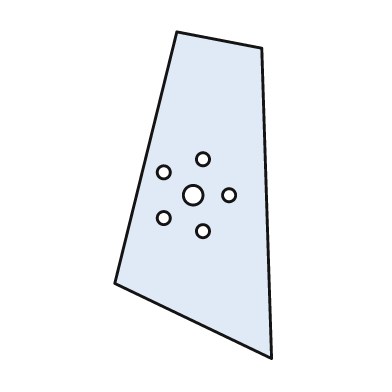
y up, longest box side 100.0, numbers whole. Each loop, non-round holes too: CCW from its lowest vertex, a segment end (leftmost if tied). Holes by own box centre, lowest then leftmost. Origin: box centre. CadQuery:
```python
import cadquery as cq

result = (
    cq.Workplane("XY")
    .moveTo(24.0, -50.0)
    .lineTo(21.0, 45.0)
    .lineTo(-5.0, 50.0)
    .lineTo(-24.0, -27.0)
    .close()
    .moveTo(3.0, -11.0)
    .circle(2.0)
    .moveTo(-9.0, -7.0)
    .circle(2.0)
    .moveTo(0.0, 0.0)
    .circle(3.0)
    .moveTo(11.0, 0.0)
    .circle(2.0)
    .moveTo(-9.0, 7.0)
    .circle(2.0)
    .moveTo(3.0, 11.0)
    .circle(2.0)
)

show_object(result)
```